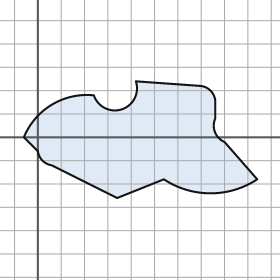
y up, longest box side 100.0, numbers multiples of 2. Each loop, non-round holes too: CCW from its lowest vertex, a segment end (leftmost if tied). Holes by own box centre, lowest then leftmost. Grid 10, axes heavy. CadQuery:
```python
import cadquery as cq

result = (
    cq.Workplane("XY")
    .moveTo(34.0, -26.0)
    .lineTo(54.0, -18.0)
    .threePointArc((74.0, -24.0), (94.0, -18.0))
    .lineTo(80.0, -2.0)
    .threePointArc((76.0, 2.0), (76.0, 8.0))
    .lineTo(76.0, 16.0)
    .threePointArc((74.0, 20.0), (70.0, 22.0))
    .lineTo(42.0, 24.0)
    .threePointArc((36.0, 12.0), (24.0, 18.0))
    .threePointArc((6.0, 14.0), (-6.0, 0.0))
    .lineTo(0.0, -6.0)
    .threePointArc((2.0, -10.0), (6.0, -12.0))
    .close()
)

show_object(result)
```